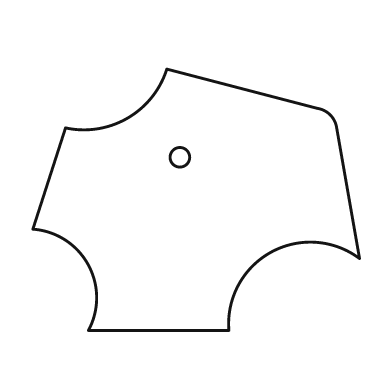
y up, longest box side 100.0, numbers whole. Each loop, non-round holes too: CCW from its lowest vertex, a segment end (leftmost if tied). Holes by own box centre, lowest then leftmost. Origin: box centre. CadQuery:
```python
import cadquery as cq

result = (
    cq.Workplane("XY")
    .moveTo(-33.0, -40.0)
    .lineTo(10.0, -40.0)
    .threePointArc((23.0, -16.0), (50.0, -18.0))
    .lineTo(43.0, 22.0)
    .threePointArc((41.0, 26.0), (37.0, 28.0))
    .lineTo(-9.0, 40.0)
    .threePointArc((-21.0, 25.0), (-40.0, 22.0))
    .lineTo(-50.0, -9.0)
    .threePointArc((-33.0, -20.0), (-33.0, -40.0))
    .close()
    .moveTo(-5.0, 13.0)
    .circle(3.0)
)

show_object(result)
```